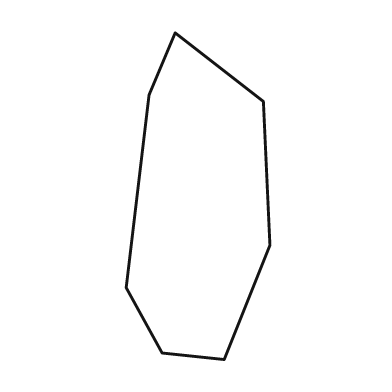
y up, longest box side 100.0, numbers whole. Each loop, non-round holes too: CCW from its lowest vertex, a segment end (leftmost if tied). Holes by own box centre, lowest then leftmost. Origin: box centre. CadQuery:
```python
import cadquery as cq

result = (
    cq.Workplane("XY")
    .moveTo(8.0, -50.0)
    .lineTo(22.0, -15.0)
    .lineTo(20.0, 29.0)
    .lineTo(-7.0, 50.0)
    .lineTo(-15.0, 31.0)
    .lineTo(-22.0, -28.0)
    .lineTo(-11.0, -48.0)
    .close()
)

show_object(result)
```